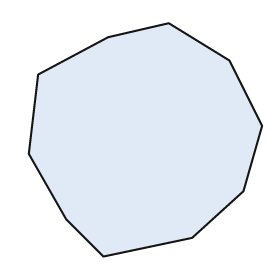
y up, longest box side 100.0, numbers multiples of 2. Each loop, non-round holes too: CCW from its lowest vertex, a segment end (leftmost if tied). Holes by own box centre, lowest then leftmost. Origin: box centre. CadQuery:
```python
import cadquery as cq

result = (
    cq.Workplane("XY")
    .moveTo(-18.0, -50.0)
    .lineTo(20.0, -42.0)
    .lineTo(42.0, -22.0)
    .lineTo(50.0, 6.0)
    .lineTo(36.0, 34.0)
    .lineTo(10.0, 50.0)
    .lineTo(-16.0, 44.0)
    .lineTo(-46.0, 28.0)
    .lineTo(-50.0, -6.0)
    .lineTo(-34.0, -34.0)
    .close()
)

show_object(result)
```